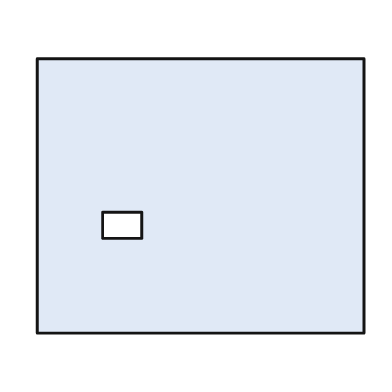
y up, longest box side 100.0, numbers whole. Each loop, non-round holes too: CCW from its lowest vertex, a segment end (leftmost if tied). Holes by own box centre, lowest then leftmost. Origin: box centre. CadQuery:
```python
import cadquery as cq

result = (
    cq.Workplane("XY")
    .moveTo(-50.0, -42.0)
    .lineTo(50.0, -42.0)
    .lineTo(50.0, 42.0)
    .lineTo(-50.0, 42.0)
    .close()
    .moveTo(-30.0, -13.0)
    .lineTo(-18.0, -13.0)
    .lineTo(-18.0, -5.0)
    .lineTo(-30.0, -5.0)
    .close()
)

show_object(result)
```